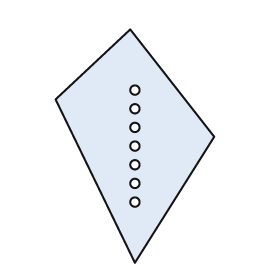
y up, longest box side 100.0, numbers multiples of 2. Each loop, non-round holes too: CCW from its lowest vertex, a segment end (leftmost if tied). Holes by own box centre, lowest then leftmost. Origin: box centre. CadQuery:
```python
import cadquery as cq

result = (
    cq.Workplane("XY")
    .moveTo(0.0, -50.0)
    .lineTo(34.0, 4.0)
    .lineTo(-2.0, 50.0)
    .lineTo(-34.0, 20.0)
    .close()
    .moveTo(0.0, -24.0)
    .circle(2.0)
    .moveTo(0.0, -16.0)
    .circle(2.0)
    .moveTo(0.0, -8.0)
    .circle(2.0)
    .moveTo(0.0, 0.0)
    .circle(2.0)
    .moveTo(0.0, 8.0)
    .circle(2.0)
    .moveTo(0.0, 16.0)
    .circle(2.0)
    .moveTo(0.0, 24.0)
    .circle(2.0)
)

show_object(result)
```